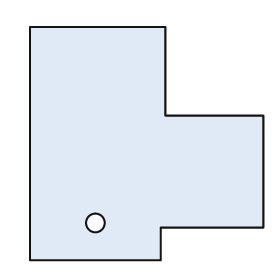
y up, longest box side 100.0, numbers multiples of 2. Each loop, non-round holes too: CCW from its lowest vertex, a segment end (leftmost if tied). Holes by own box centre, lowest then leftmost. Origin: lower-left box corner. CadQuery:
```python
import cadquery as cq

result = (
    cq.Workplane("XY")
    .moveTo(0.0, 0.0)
    .lineTo(56.0, 0.0)
    .lineTo(56.0, 14.0)
    .lineTo(100.0, 14.0)
    .lineTo(100.0, 62.0)
    .lineTo(58.0, 62.0)
    .lineTo(58.0, 100.0)
    .lineTo(0.0, 100.0)
    .close()
    .moveTo(28.0, 16.0)
    .circle(4.0)
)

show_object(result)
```